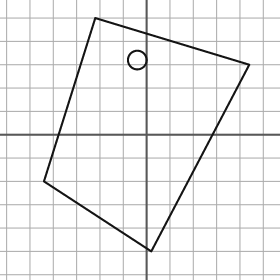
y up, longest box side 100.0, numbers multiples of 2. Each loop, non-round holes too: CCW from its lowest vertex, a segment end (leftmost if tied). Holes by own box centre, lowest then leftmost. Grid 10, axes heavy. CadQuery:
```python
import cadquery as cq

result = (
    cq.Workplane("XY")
    .moveTo(2.0, -50.0)
    .lineTo(44.0, 30.0)
    .lineTo(-22.0, 50.0)
    .lineTo(-44.0, -20.0)
    .close()
    .moveTo(-4.0, 32.0)
    .circle(4.0)
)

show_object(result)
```